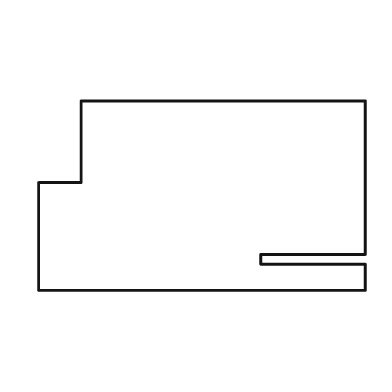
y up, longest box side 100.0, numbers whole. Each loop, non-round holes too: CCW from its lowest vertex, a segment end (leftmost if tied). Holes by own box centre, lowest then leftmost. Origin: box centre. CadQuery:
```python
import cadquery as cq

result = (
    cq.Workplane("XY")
    .moveTo(-50.0, -29.0)
    .lineTo(50.0, -29.0)
    .lineTo(50.0, -21.0)
    .lineTo(18.0, -21.0)
    .lineTo(18.0, -18.0)
    .lineTo(50.0, -18.0)
    .lineTo(50.0, 29.0)
    .lineTo(-37.0, 29.0)
    .lineTo(-37.0, 4.0)
    .lineTo(-50.0, 4.0)
    .close()
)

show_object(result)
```